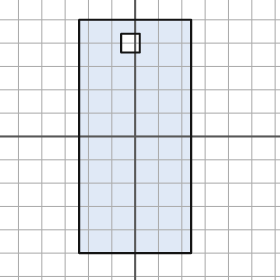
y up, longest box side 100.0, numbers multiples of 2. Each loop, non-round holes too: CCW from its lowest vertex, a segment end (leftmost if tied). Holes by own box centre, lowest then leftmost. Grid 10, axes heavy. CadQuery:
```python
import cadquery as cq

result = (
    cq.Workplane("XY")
    .moveTo(-24.0, -50.0)
    .lineTo(24.0, -50.0)
    .lineTo(24.0, 50.0)
    .lineTo(-24.0, 50.0)
    .close()
    .moveTo(-6.0, 36.0)
    .lineTo(2.0, 36.0)
    .lineTo(2.0, 44.0)
    .lineTo(-6.0, 44.0)
    .close()
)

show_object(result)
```